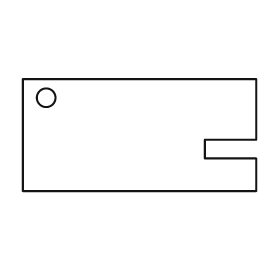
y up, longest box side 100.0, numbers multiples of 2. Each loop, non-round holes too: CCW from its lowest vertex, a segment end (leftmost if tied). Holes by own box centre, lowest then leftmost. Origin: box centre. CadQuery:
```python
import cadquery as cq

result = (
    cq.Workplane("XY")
    .moveTo(-50.0, -24.0)
    .lineTo(50.0, -24.0)
    .lineTo(50.0, -10.0)
    .lineTo(28.0, -10.0)
    .lineTo(28.0, -2.0)
    .lineTo(50.0, -2.0)
    .lineTo(50.0, 24.0)
    .lineTo(-50.0, 24.0)
    .close()
    .moveTo(-40.0, 16.0)
    .circle(4.0)
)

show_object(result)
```